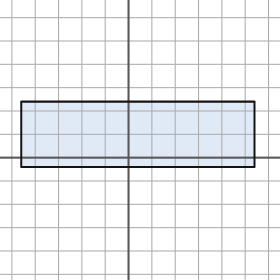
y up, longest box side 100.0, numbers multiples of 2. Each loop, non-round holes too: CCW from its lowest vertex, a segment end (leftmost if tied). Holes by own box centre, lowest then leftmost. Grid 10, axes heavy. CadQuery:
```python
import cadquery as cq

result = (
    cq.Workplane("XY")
    .moveTo(-46.0, -4.0)
    .lineTo(54.0, -4.0)
    .lineTo(54.0, 24.0)
    .lineTo(-46.0, 24.0)
    .close()
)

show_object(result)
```